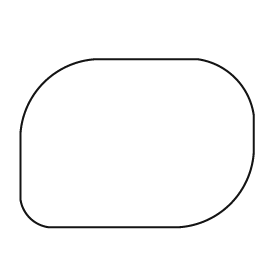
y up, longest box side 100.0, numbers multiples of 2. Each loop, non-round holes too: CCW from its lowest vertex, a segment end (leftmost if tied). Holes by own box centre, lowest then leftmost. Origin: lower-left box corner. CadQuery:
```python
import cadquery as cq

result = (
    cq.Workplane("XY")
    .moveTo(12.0, 0.0)
    .lineTo(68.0, 0.0)
    .threePointArc((90.0, 10.0), (100.0, 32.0))
    .lineTo(100.0, 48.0)
    .threePointArc((92.0, 64.0), (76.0, 72.0))
    .lineTo(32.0, 72.0)
    .threePointArc((10.0, 62.0), (0.0, 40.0))
    .lineTo(0.0, 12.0)
    .threePointArc((4.0, 4.0), (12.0, 0.0))
    .close()
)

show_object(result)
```